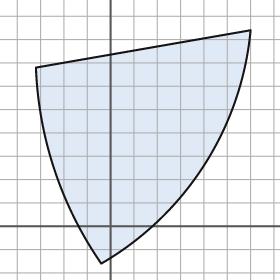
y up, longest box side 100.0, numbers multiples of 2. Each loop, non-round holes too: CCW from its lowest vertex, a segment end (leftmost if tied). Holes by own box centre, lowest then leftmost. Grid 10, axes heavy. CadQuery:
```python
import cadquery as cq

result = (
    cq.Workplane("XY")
    .moveTo(-4.0, -16.0)
    .threePointArc((40.0, 26.0), (60.0, 84.0))
    .lineTo(-32.0, 68.0)
    .threePointArc((-24.0, 24.0), (-4.0, -16.0))
    .close()
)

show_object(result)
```